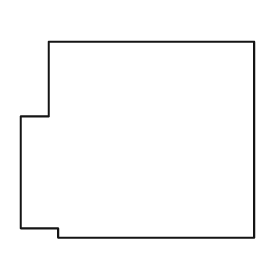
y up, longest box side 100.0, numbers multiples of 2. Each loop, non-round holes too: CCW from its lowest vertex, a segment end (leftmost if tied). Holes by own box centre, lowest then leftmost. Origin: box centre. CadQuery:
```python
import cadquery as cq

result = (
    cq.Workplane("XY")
    .moveTo(-34.0, -42.0)
    .lineTo(50.0, -42.0)
    .lineTo(50.0, 42.0)
    .lineTo(-38.0, 42.0)
    .lineTo(-38.0, 10.0)
    .lineTo(-50.0, 10.0)
    .lineTo(-50.0, -38.0)
    .lineTo(-34.0, -38.0)
    .close()
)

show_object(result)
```